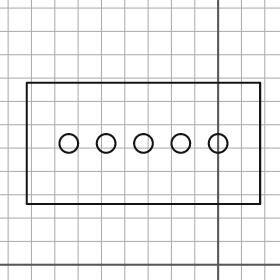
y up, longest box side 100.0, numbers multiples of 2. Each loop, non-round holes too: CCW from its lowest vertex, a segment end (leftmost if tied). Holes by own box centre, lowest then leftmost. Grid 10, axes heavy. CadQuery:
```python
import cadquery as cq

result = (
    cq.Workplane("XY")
    .moveTo(-82.0, 26.0)
    .lineTo(18.0, 26.0)
    .lineTo(18.0, 78.0)
    .lineTo(-82.0, 78.0)
    .close()
    .moveTo(-64.0, 52.0)
    .circle(4.0)
    .moveTo(-48.0, 52.0)
    .circle(4.0)
    .moveTo(-32.0, 52.0)
    .circle(4.0)
    .moveTo(-16.0, 52.0)
    .circle(4.0)
    .moveTo(0.0, 52.0)
    .circle(4.0)
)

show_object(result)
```